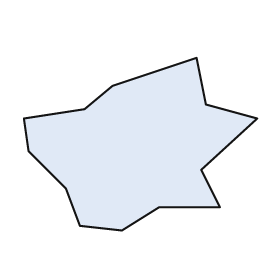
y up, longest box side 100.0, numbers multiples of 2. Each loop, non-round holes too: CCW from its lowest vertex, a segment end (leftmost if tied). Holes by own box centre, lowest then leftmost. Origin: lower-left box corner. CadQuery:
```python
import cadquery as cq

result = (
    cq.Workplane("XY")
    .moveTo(42.0, 0.0)
    .lineTo(58.0, 10.0)
    .lineTo(84.0, 10.0)
    .lineTo(76.0, 26.0)
    .lineTo(100.0, 48.0)
    .lineTo(78.0, 54.0)
    .lineTo(74.0, 74.0)
    .lineTo(38.0, 62.0)
    .lineTo(26.0, 52.0)
    .lineTo(0.0, 48.0)
    .lineTo(2.0, 34.0)
    .lineTo(18.0, 18.0)
    .lineTo(24.0, 2.0)
    .close()
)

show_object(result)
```